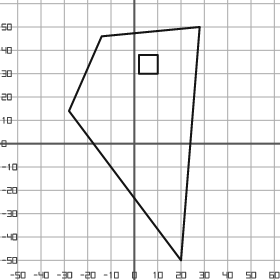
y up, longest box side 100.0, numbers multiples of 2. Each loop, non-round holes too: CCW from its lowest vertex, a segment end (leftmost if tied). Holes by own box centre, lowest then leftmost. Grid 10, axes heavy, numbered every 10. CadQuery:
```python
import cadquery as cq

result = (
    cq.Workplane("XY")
    .moveTo(20.0, -50.0)
    .lineTo(28.0, 50.0)
    .lineTo(-14.0, 46.0)
    .lineTo(-28.0, 14.0)
    .close()
    .moveTo(2.0, 30.0)
    .lineTo(10.0, 30.0)
    .lineTo(10.0, 38.0)
    .lineTo(2.0, 38.0)
    .close()
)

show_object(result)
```